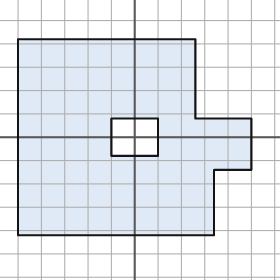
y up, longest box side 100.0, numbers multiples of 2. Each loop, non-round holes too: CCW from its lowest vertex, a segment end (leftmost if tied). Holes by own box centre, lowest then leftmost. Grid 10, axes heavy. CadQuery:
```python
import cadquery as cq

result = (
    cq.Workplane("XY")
    .moveTo(-50.0, -42.0)
    .lineTo(34.0, -42.0)
    .lineTo(34.0, -14.0)
    .lineTo(50.0, -14.0)
    .lineTo(50.0, 8.0)
    .lineTo(26.0, 8.0)
    .lineTo(26.0, 42.0)
    .lineTo(-50.0, 42.0)
    .close()
    .moveTo(-10.0, -8.0)
    .lineTo(10.0, -8.0)
    .lineTo(10.0, 8.0)
    .lineTo(-10.0, 8.0)
    .close()
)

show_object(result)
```